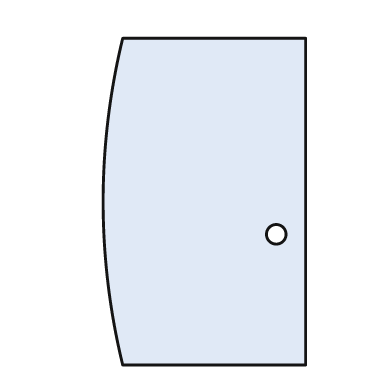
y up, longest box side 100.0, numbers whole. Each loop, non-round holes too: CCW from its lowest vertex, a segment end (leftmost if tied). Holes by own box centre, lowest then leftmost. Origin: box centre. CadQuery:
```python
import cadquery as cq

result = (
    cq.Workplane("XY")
    .moveTo(-25.0, -50.0)
    .lineTo(31.0, -50.0)
    .lineTo(31.0, 50.0)
    .lineTo(-25.0, 50.0)
    .threePointArc((-31.0, 0.0), (-25.0, -50.0))
    .close()
    .moveTo(22.0, -10.0)
    .circle(3.0)
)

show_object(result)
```